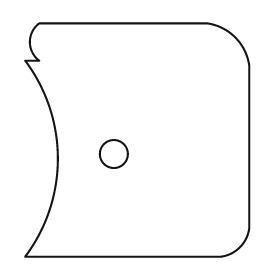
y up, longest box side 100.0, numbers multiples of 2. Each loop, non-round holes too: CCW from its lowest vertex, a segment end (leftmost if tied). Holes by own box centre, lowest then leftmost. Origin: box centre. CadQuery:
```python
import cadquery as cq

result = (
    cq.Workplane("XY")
    .moveTo(-48.0, -50.0)
    .lineTo(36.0, -50.0)
    .threePointArc((44.0, -46.0), (48.0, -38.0))
    .lineTo(48.0, 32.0)
    .threePointArc((42.0, 44.0), (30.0, 50.0))
    .lineTo(-42.0, 50.0)
    .threePointArc((-46.0, 42.0), (-42.0, 34.0))
    .lineTo(-48.0, 34.0)
    .threePointArc((-34.0, -8.0), (-48.0, -50.0))
    .close()
    .moveTo(-10.0, -6.0)
    .circle(6.0)
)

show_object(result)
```